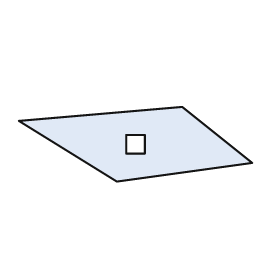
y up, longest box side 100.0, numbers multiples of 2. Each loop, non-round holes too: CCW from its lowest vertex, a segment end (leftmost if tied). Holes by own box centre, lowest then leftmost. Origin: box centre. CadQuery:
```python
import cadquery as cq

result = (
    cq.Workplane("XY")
    .moveTo(-8.0, -16.0)
    .lineTo(50.0, -8.0)
    .lineTo(20.0, 16.0)
    .lineTo(-50.0, 10.0)
    .close()
    .moveTo(-4.0, -4.0)
    .lineTo(4.0, -4.0)
    .lineTo(4.0, 4.0)
    .lineTo(-4.0, 4.0)
    .close()
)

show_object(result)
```